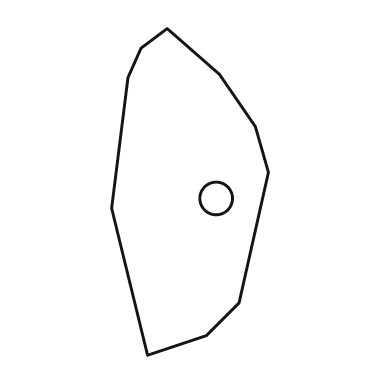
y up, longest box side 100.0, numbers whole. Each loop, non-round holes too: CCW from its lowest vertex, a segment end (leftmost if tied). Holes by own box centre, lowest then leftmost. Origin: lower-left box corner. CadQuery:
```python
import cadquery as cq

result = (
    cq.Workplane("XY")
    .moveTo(11.0, 0.0)
    .lineTo(29.0, 6.0)
    .lineTo(39.0, 16.0)
    .lineTo(48.0, 56.0)
    .lineTo(44.0, 70.0)
    .lineTo(33.0, 86.0)
    .lineTo(17.0, 100.0)
    .lineTo(9.0, 94.0)
    .lineTo(5.0, 85.0)
    .lineTo(0.0, 45.0)
    .close()
    .moveTo(32.0, 48.0)
    .circle(5.0)
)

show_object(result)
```